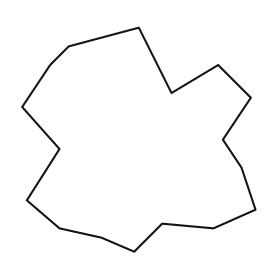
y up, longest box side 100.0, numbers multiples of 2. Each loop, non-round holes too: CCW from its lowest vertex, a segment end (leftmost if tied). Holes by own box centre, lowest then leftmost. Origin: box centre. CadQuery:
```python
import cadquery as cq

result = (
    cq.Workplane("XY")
    .moveTo(-2.0, -48.0)
    .lineTo(10.0, -36.0)
    .lineTo(32.0, -38.0)
    .lineTo(50.0, -30.0)
    .lineTo(44.0, -12.0)
    .lineTo(36.0, 0.0)
    .lineTo(48.0, 18.0)
    .lineTo(34.0, 32.0)
    .lineTo(14.0, 20.0)
    .lineTo(0.0, 48.0)
    .lineTo(-30.0, 40.0)
    .lineTo(-38.0, 32.0)
    .lineTo(-50.0, 14.0)
    .lineTo(-34.0, -4.0)
    .lineTo(-48.0, -26.0)
    .lineTo(-34.0, -38.0)
    .lineTo(-16.0, -42.0)
    .close()
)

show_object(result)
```